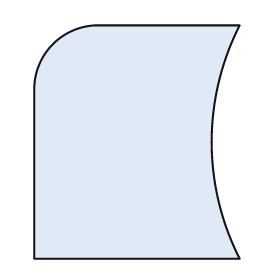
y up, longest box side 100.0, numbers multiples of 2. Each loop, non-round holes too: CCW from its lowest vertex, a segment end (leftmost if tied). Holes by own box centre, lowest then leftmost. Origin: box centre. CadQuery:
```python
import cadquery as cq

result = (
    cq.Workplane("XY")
    .moveTo(-44.0, -50.0)
    .lineTo(44.0, -50.0)
    .threePointArc((32.0, 0.0), (44.0, 50.0))
    .lineTo(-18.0, 50.0)
    .threePointArc((-36.0, 42.0), (-44.0, 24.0))
    .close()
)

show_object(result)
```